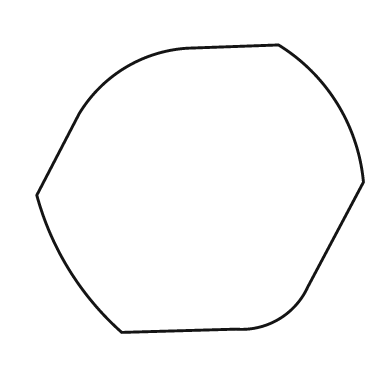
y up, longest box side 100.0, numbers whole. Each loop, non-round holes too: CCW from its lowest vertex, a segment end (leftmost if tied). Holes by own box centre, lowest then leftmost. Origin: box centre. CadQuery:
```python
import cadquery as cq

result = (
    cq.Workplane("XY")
    .moveTo(-24.0, -44.0)
    .lineTo(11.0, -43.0)
    .threePointArc((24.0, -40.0), (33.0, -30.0))
    .lineTo(50.0, 2.0)
    .threePointArc((42.0, 26.0), (24.0, 44.0))
    .lineTo(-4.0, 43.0)
    .threePointArc((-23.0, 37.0), (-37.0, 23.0))
    .lineTo(-50.0, -2.0)
    .threePointArc((-40.0, -25.0), (-24.0, -44.0))
    .close()
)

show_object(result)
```